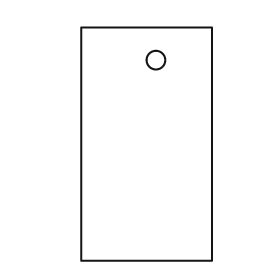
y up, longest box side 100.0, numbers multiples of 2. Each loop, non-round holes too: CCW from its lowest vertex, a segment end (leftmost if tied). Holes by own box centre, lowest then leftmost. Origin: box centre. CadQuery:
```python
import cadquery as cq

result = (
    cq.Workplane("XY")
    .moveTo(-28.0, -50.0)
    .lineTo(28.0, -50.0)
    .lineTo(28.0, 50.0)
    .lineTo(-28.0, 50.0)
    .close()
    .moveTo(4.0, 36.0)
    .circle(4.0)
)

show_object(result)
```